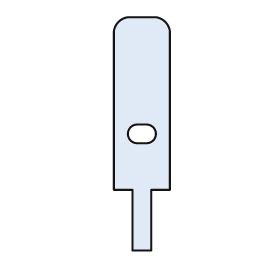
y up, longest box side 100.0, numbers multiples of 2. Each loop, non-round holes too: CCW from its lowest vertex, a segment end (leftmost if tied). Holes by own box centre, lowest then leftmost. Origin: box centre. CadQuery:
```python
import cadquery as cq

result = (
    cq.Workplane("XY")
    .moveTo(-4.0, -50.0)
    .lineTo(4.0, -50.0)
    .lineTo(4.0, -24.0)
    .lineTo(12.0, -24.0)
    .lineTo(12.0, 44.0)
    .threePointArc((10.0, 48.0), (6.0, 50.0))
    .lineTo(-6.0, 50.0)
    .threePointArc((-10.0, 48.0), (-12.0, 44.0))
    .lineTo(-12.0, -24.0)
    .lineTo(-4.0, -24.0)
    .close()
    .moveTo(-2.0, -4.0)
    .lineTo(2.0, -4.0)
    .threePointArc((6.0, 0.0), (2.0, 4.0))
    .lineTo(-2.0, 4.0)
    .threePointArc((-6.0, 0.0), (-2.0, -4.0))
    .close()
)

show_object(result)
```